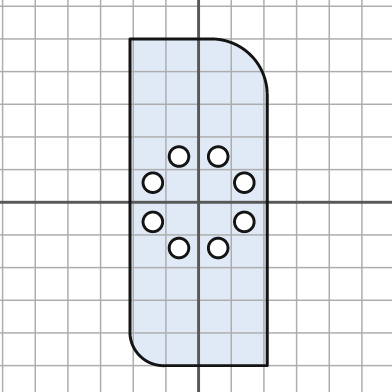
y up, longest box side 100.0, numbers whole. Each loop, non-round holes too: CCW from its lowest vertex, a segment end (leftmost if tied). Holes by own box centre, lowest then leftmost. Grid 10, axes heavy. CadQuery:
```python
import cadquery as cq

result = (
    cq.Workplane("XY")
    .moveTo(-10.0, -50.0)
    .lineTo(21.0, -50.0)
    .lineTo(21.0, 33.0)
    .threePointArc((16.0, 45.0), (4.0, 50.0))
    .lineTo(-21.0, 50.0)
    .lineTo(-21.0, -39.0)
    .threePointArc((-18.0, -47.0), (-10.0, -50.0))
    .close()
    .moveTo(-6.0, -14.0)
    .circle(3.0)
    .moveTo(6.0, -14.0)
    .circle(3.0)
    .moveTo(-14.0, -6.0)
    .circle(3.0)
    .moveTo(14.0, -6.0)
    .circle(3.0)
    .moveTo(-14.0, 6.0)
    .circle(3.0)
    .moveTo(14.0, 6.0)
    .circle(3.0)
    .moveTo(-6.0, 14.0)
    .circle(3.0)
    .moveTo(6.0, 14.0)
    .circle(3.0)
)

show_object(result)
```